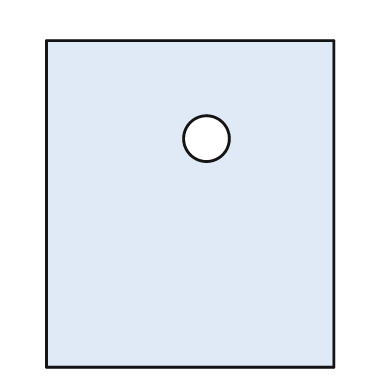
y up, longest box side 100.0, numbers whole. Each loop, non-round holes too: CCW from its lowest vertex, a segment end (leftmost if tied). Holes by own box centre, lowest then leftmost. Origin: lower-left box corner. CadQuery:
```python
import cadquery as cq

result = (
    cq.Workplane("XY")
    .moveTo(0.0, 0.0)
    .lineTo(88.0, 0.0)
    .lineTo(88.0, 100.0)
    .lineTo(0.0, 100.0)
    .close()
    .moveTo(49.0, 70.0)
    .circle(7.0)
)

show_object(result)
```